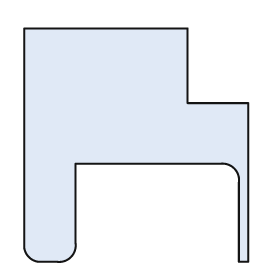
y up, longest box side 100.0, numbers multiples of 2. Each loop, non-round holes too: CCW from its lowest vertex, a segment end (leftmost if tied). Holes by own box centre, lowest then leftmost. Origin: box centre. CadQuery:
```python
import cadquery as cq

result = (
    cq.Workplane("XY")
    .moveTo(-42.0, -50.0)
    .lineTo(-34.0, -50.0)
    .threePointArc((-28.0, -48.0), (-26.0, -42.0))
    .lineTo(-26.0, -8.0)
    .lineTo(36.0, -8.0)
    .threePointArc((42.0, -10.0), (44.0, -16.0))
    .lineTo(44.0, -50.0)
    .lineTo(48.0, -50.0)
    .lineTo(48.0, 18.0)
    .lineTo(22.0, 18.0)
    .lineTo(22.0, 50.0)
    .lineTo(-48.0, 50.0)
    .lineTo(-48.0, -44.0)
    .threePointArc((-46.0, -48.0), (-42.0, -50.0))
    .close()
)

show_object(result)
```